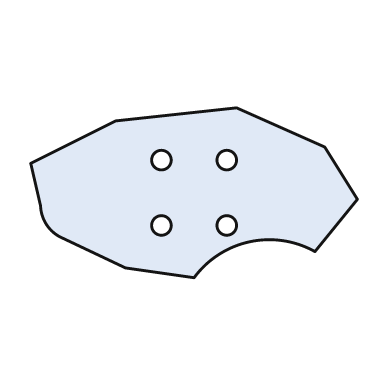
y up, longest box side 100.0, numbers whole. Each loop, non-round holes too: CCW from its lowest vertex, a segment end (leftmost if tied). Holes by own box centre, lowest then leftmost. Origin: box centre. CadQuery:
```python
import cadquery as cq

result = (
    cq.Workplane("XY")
    .moveTo(0.0, -26.0)
    .threePointArc((17.0, -15.0), (37.0, -18.0))
    .lineTo(50.0, -2.0)
    .lineTo(40.0, 14.0)
    .lineTo(13.0, 26.0)
    .lineTo(-24.0, 22.0)
    .lineTo(-50.0, 9.0)
    .lineTo(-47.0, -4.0)
    .threePointArc((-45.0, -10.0), (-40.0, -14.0))
    .lineTo(-21.0, -23.0)
    .close()
    .moveTo(-10.0, -10.0)
    .circle(3.0)
    .moveTo(10.0, -10.0)
    .circle(3.0)
    .moveTo(-10.0, 10.0)
    .circle(3.0)
    .moveTo(10.0, 10.0)
    .circle(3.0)
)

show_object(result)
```